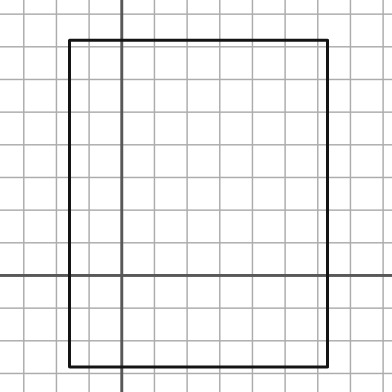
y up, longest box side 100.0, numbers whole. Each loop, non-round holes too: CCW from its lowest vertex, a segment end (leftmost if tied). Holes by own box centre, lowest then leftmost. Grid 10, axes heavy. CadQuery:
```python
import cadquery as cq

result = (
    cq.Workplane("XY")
    .moveTo(-16.0, -28.0)
    .lineTo(63.0, -28.0)
    .lineTo(63.0, 72.0)
    .lineTo(-16.0, 72.0)
    .close()
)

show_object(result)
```